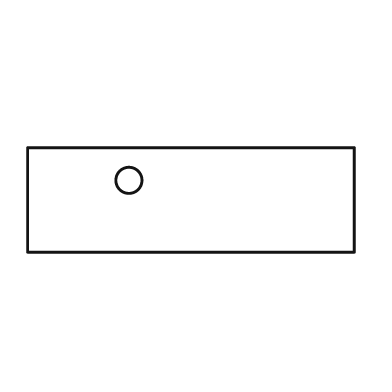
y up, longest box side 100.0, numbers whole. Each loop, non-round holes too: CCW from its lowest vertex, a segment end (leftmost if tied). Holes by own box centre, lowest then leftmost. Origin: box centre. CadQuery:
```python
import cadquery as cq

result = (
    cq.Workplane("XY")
    .moveTo(-50.0, -16.0)
    .lineTo(50.0, -16.0)
    .lineTo(50.0, 16.0)
    .lineTo(-50.0, 16.0)
    .close()
    .moveTo(-19.0, 6.0)
    .circle(4.0)
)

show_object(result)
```